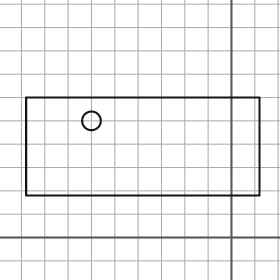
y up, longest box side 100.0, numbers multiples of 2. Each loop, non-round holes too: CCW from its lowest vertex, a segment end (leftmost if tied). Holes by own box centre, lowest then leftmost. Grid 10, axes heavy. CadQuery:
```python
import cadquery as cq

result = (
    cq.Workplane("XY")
    .moveTo(-88.0, 18.0)
    .lineTo(12.0, 18.0)
    .lineTo(12.0, 60.0)
    .lineTo(-88.0, 60.0)
    .close()
    .moveTo(-60.0, 50.0)
    .circle(4.0)
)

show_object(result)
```